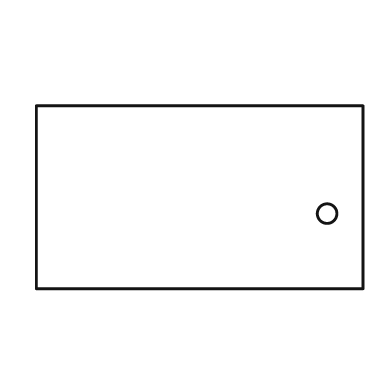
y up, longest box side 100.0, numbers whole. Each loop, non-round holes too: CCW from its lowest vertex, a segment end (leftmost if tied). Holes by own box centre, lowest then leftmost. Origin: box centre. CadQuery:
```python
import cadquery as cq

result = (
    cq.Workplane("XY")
    .moveTo(-50.0, -28.0)
    .lineTo(50.0, -28.0)
    .lineTo(50.0, 28.0)
    .lineTo(-50.0, 28.0)
    .close()
    .moveTo(39.0, -5.0)
    .circle(3.0)
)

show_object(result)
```